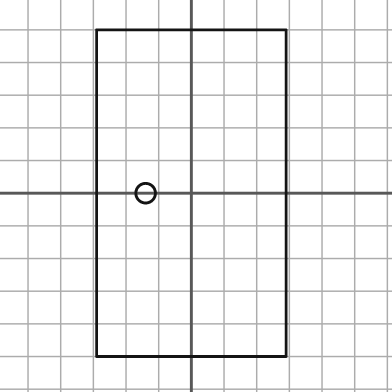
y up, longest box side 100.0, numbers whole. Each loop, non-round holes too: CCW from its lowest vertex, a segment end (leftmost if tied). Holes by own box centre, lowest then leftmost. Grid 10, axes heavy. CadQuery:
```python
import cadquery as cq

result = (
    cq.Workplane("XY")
    .moveTo(-29.0, -50.0)
    .lineTo(29.0, -50.0)
    .lineTo(29.0, 50.0)
    .lineTo(-29.0, 50.0)
    .close()
    .moveTo(-14.0, 0.0)
    .circle(3.0)
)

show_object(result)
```